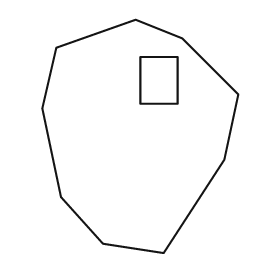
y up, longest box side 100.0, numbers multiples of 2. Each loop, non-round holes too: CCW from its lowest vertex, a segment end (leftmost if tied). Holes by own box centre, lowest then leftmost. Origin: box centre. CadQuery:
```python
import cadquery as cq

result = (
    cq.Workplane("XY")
    .moveTo(10.0, -50.0)
    .lineTo(36.0, -10.0)
    .lineTo(42.0, 18.0)
    .lineTo(18.0, 42.0)
    .lineTo(-2.0, 50.0)
    .lineTo(-36.0, 38.0)
    .lineTo(-42.0, 12.0)
    .lineTo(-34.0, -26.0)
    .lineTo(-16.0, -46.0)
    .close()
    .moveTo(0.0, 14.0)
    .lineTo(16.0, 14.0)
    .lineTo(16.0, 34.0)
    .lineTo(0.0, 34.0)
    .close()
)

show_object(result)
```